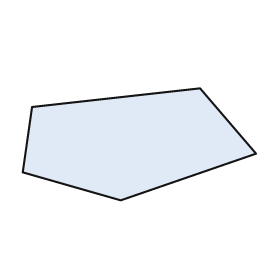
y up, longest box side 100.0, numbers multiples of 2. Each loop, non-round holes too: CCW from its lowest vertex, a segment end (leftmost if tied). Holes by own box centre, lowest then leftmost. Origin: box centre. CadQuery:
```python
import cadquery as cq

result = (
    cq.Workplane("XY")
    .moveTo(-8.0, -24.0)
    .lineTo(50.0, -4.0)
    .lineTo(26.0, 24.0)
    .lineTo(-46.0, 16.0)
    .lineTo(-50.0, -12.0)
    .close()
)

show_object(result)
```